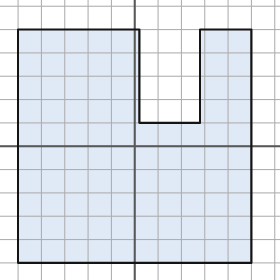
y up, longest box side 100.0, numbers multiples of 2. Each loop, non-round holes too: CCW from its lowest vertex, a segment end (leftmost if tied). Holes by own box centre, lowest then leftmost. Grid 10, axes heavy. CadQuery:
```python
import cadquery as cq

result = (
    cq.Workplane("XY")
    .moveTo(-50.0, -50.0)
    .lineTo(50.0, -50.0)
    .lineTo(50.0, 50.0)
    .lineTo(28.0, 50.0)
    .lineTo(28.0, 10.0)
    .lineTo(2.0, 10.0)
    .lineTo(2.0, 50.0)
    .lineTo(-50.0, 50.0)
    .close()
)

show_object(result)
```